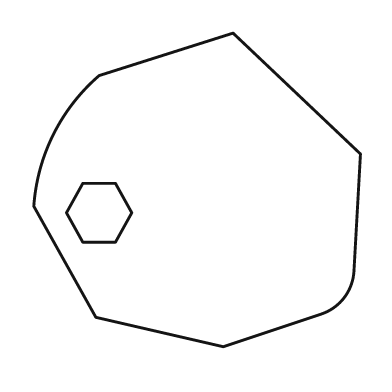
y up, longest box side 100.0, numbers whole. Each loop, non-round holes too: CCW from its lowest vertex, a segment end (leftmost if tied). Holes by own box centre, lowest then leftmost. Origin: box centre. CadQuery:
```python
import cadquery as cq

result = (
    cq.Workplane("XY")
    .moveTo(8.0, -48.0)
    .lineTo(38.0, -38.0)
    .threePointArc((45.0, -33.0), (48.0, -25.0))
    .lineTo(50.0, 11.0)
    .lineTo(11.0, 48.0)
    .lineTo(-30.0, 35.0)
    .threePointArc((-44.0, 17.0), (-50.0, -5.0))
    .lineTo(-31.0, -39.0)
    .close()
    .moveTo(-35.0, -16.0)
    .lineTo(-25.0, -16.0)
    .lineTo(-20.0, -7.0)
    .lineTo(-25.0, 2.0)
    .lineTo(-35.0, 2.0)
    .lineTo(-40.0, -7.0)
    .close()
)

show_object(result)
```